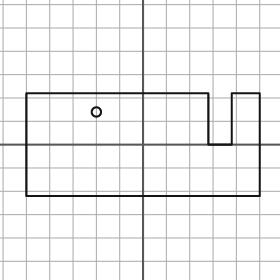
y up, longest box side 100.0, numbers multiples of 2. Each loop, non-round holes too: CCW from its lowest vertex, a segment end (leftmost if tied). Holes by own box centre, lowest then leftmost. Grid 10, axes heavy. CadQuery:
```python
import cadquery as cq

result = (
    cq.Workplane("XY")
    .moveTo(-50.0, -22.0)
    .lineTo(50.0, -22.0)
    .lineTo(50.0, 22.0)
    .lineTo(38.0, 22.0)
    .lineTo(38.0, 0.0)
    .lineTo(28.0, 0.0)
    .lineTo(28.0, 22.0)
    .lineTo(-50.0, 22.0)
    .close()
    .moveTo(-20.0, 14.0)
    .circle(2.0)
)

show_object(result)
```